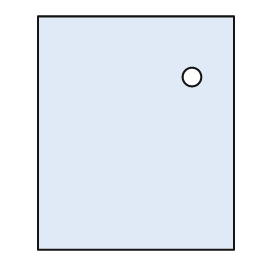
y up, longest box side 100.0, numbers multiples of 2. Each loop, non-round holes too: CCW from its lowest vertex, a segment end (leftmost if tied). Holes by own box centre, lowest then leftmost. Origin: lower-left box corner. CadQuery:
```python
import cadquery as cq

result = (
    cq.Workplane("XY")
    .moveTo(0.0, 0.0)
    .lineTo(84.0, 0.0)
    .lineTo(84.0, 100.0)
    .lineTo(0.0, 100.0)
    .close()
    .moveTo(66.0, 74.0)
    .circle(4.0)
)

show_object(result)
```